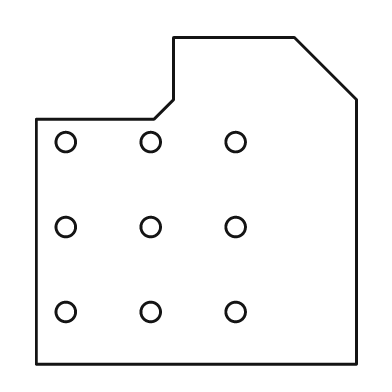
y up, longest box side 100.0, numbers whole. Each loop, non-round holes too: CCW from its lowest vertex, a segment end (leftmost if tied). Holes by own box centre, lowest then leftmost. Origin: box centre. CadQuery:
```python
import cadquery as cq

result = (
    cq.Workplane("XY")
    .moveTo(-49.0, -50.0)
    .lineTo(49.0, -50.0)
    .lineTo(49.0, 31.0)
    .lineTo(30.0, 50.0)
    .lineTo(-7.0, 50.0)
    .lineTo(-7.0, 31.0)
    .lineTo(-13.0, 25.0)
    .lineTo(-49.0, 25.0)
    .close()
    .moveTo(-40.0, -34.0)
    .circle(3.0)
    .moveTo(-14.0, -34.0)
    .circle(3.0)
    .moveTo(12.0, -34.0)
    .circle(3.0)
    .moveTo(-40.0, -8.0)
    .circle(3.0)
    .moveTo(-14.0, -8.0)
    .circle(3.0)
    .moveTo(12.0, -8.0)
    .circle(3.0)
    .moveTo(-40.0, 18.0)
    .circle(3.0)
    .moveTo(-14.0, 18.0)
    .circle(3.0)
    .moveTo(12.0, 18.0)
    .circle(3.0)
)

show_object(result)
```